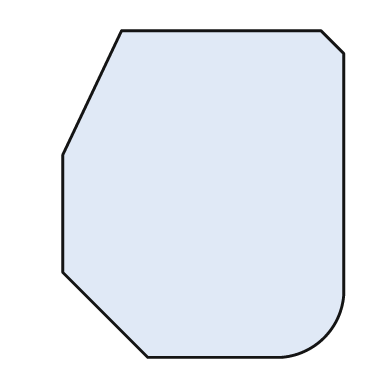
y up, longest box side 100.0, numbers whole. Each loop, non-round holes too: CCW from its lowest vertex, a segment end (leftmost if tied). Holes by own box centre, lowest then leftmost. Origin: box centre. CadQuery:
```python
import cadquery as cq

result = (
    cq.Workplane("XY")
    .moveTo(-17.0, -50.0)
    .lineTo(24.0, -50.0)
    .threePointArc((37.0, -44.0), (43.0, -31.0))
    .lineTo(43.0, 43.0)
    .lineTo(36.0, 50.0)
    .lineTo(-25.0, 50.0)
    .lineTo(-43.0, 12.0)
    .lineTo(-43.0, -24.0)
    .close()
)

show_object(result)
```